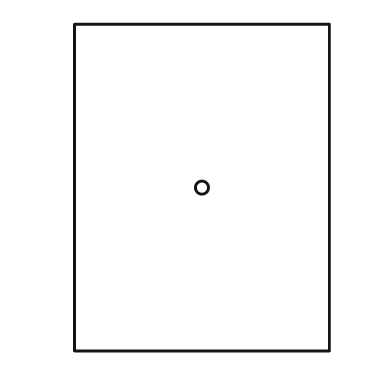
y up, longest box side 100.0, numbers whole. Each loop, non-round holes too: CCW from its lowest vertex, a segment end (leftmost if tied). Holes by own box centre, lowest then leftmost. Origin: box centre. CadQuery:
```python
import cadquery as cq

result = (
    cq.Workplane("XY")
    .moveTo(-39.0, -50.0)
    .lineTo(39.0, -50.0)
    .lineTo(39.0, 50.0)
    .lineTo(-39.0, 50.0)
    .close()
    .moveTo(0.0, 0.0)
    .circle(2.0)
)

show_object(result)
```